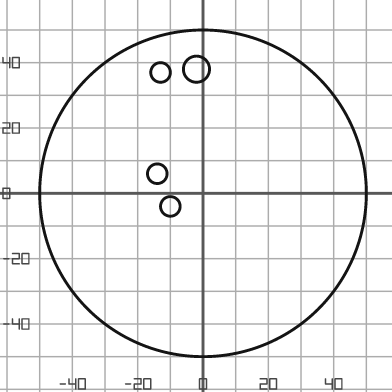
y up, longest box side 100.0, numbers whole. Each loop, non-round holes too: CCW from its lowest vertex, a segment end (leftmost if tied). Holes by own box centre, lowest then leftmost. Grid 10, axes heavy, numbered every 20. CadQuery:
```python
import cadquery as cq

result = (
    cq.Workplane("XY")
    .moveTo(0.0, 0.0)
    .circle(50.0)
    .moveTo(-10.0, -4.0)
    .circle(3.0)
    .moveTo(-14.0, 6.0)
    .circle(3.0)
    .moveTo(-13.0, 37.0)
    .circle(3.0)
    .moveTo(-2.0, 38.0)
    .circle(4.0)
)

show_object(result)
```